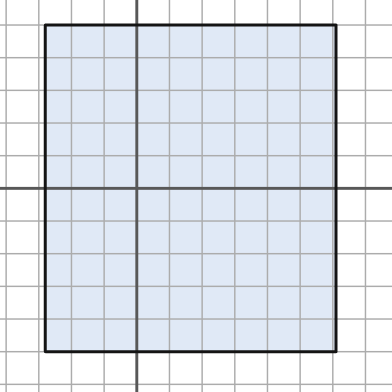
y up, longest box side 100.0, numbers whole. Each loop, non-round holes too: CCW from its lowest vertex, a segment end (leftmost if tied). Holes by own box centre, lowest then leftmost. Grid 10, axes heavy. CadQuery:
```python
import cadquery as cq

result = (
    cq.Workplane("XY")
    .moveTo(-28.0, -50.0)
    .lineTo(61.0, -50.0)
    .lineTo(61.0, 50.0)
    .lineTo(-28.0, 50.0)
    .close()
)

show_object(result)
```